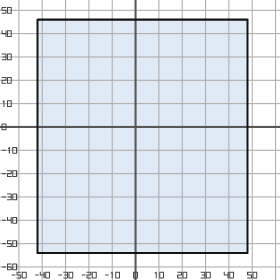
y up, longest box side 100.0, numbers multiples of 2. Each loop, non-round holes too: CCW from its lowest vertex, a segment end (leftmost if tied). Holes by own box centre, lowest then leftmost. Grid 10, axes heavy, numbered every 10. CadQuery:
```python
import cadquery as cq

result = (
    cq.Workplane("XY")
    .moveTo(-42.0, -54.0)
    .lineTo(48.0, -54.0)
    .lineTo(48.0, 46.0)
    .lineTo(-42.0, 46.0)
    .close()
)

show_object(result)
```